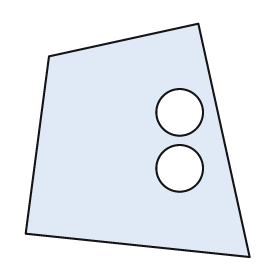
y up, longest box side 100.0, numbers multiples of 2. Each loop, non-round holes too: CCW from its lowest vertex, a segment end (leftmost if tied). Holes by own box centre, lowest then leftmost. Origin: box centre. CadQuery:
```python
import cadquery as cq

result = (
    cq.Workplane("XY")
    .moveTo(48.0, -50.0)
    .lineTo(26.0, 50.0)
    .lineTo(-38.0, 36.0)
    .lineTo(-48.0, -40.0)
    .close()
    .moveTo(18.0, -12.0)
    .circle(10.0)
    .moveTo(18.0, 12.0)
    .circle(10.0)
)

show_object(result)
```